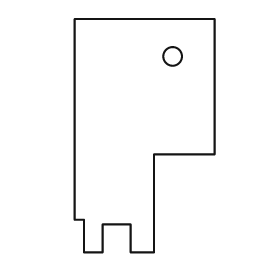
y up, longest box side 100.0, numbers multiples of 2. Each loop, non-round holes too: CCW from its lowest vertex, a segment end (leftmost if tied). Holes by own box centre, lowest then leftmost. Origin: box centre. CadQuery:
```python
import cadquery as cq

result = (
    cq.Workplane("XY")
    .moveTo(-26.0, -50.0)
    .lineTo(-18.0, -50.0)
    .lineTo(-18.0, -38.0)
    .lineTo(-6.0, -38.0)
    .lineTo(-6.0, -50.0)
    .lineTo(4.0, -50.0)
    .lineTo(4.0, -8.0)
    .lineTo(30.0, -8.0)
    .lineTo(30.0, 50.0)
    .lineTo(-30.0, 50.0)
    .lineTo(-30.0, -36.0)
    .lineTo(-26.0, -36.0)
    .close()
    .moveTo(12.0, 34.0)
    .circle(4.0)
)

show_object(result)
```